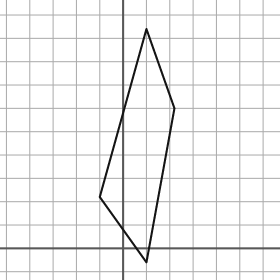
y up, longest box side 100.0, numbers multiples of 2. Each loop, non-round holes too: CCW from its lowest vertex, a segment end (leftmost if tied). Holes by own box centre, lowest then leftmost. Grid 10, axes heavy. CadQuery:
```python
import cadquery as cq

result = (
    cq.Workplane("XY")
    .moveTo(10.0, -6.0)
    .lineTo(22.0, 60.0)
    .lineTo(10.0, 94.0)
    .lineTo(-10.0, 22.0)
    .close()
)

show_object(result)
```